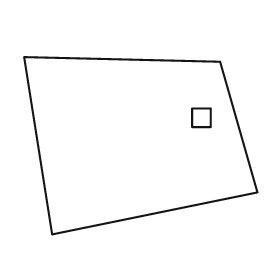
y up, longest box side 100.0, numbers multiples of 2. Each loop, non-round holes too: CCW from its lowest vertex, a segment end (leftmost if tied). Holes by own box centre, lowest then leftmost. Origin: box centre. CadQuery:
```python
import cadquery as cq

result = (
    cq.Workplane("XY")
    .moveTo(-38.0, -38.0)
    .lineTo(50.0, -20.0)
    .lineTo(34.0, 36.0)
    .lineTo(-50.0, 38.0)
    .close()
    .moveTo(22.0, 8.0)
    .lineTo(30.0, 8.0)
    .lineTo(30.0, 16.0)
    .lineTo(22.0, 16.0)
    .close()
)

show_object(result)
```